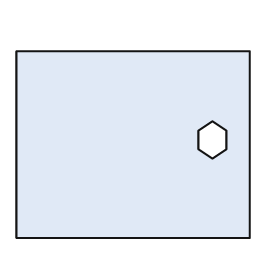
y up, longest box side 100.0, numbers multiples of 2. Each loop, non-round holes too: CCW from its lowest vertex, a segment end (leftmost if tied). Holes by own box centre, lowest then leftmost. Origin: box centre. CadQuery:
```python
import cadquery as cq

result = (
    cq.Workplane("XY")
    .moveTo(-50.0, -40.0)
    .lineTo(50.0, -40.0)
    .lineTo(50.0, 40.0)
    .lineTo(-50.0, 40.0)
    .close()
    .moveTo(34.0, -6.0)
    .lineTo(40.0, -2.0)
    .lineTo(40.0, 6.0)
    .lineTo(34.0, 10.0)
    .lineTo(28.0, 6.0)
    .lineTo(28.0, -2.0)
    .close()
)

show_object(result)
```